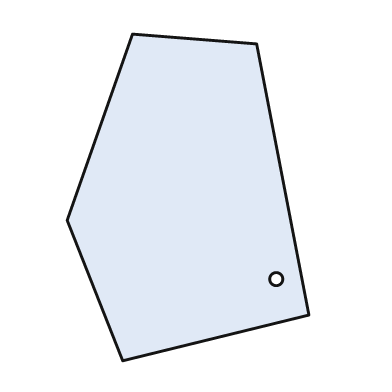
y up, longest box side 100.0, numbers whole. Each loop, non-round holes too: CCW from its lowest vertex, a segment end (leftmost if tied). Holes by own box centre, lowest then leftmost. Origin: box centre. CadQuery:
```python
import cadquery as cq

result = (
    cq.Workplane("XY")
    .moveTo(-20.0, -50.0)
    .lineTo(37.0, -36.0)
    .lineTo(21.0, 47.0)
    .lineTo(-17.0, 50.0)
    .lineTo(-37.0, -7.0)
    .close()
    .moveTo(27.0, -25.0)
    .circle(2.0)
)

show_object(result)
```